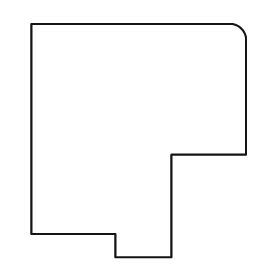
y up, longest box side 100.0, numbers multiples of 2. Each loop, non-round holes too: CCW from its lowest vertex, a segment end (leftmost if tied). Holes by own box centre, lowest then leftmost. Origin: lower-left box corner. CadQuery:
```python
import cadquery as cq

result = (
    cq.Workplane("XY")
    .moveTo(36.0, 0.0)
    .lineTo(60.0, 0.0)
    .lineTo(60.0, 44.0)
    .lineTo(92.0, 44.0)
    .lineTo(92.0, 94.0)
    .threePointArc((90.0, 98.0), (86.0, 100.0))
    .lineTo(0.0, 100.0)
    .lineTo(0.0, 10.0)
    .lineTo(36.0, 10.0)
    .close()
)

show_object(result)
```